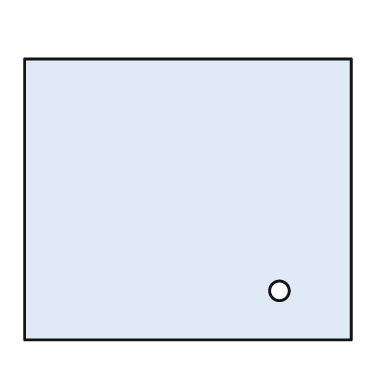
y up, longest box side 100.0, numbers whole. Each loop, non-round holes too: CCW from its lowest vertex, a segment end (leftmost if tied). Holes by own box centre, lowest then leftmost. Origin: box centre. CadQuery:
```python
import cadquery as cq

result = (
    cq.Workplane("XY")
    .moveTo(-50.0, -43.0)
    .lineTo(50.0, -43.0)
    .lineTo(50.0, 43.0)
    .lineTo(-50.0, 43.0)
    .close()
    .moveTo(28.0, -28.0)
    .circle(3.0)
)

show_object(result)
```